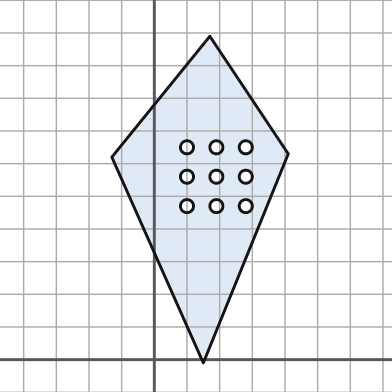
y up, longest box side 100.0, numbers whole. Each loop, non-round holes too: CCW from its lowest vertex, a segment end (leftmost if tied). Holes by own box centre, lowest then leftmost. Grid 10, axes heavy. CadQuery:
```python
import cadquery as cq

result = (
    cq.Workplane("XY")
    .moveTo(15.0, -1.0)
    .lineTo(41.0, 63.0)
    .lineTo(17.0, 99.0)
    .lineTo(-13.0, 62.0)
    .close()
    .moveTo(10.0, 47.0)
    .circle(2.0)
    .moveTo(19.0, 47.0)
    .circle(2.0)
    .moveTo(28.0, 47.0)
    .circle(2.0)
    .moveTo(10.0, 56.0)
    .circle(2.0)
    .moveTo(19.0, 56.0)
    .circle(2.0)
    .moveTo(28.0, 56.0)
    .circle(2.0)
    .moveTo(10.0, 65.0)
    .circle(2.0)
    .moveTo(19.0, 65.0)
    .circle(2.0)
    .moveTo(28.0, 65.0)
    .circle(2.0)
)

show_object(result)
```